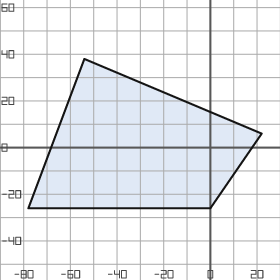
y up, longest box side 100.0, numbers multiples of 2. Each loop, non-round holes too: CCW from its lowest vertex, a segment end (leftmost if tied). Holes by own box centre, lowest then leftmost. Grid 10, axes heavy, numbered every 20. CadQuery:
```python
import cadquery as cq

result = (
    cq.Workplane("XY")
    .moveTo(-78.0, -26.0)
    .lineTo(0.0, -26.0)
    .lineTo(22.0, 6.0)
    .lineTo(-54.0, 38.0)
    .close()
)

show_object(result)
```